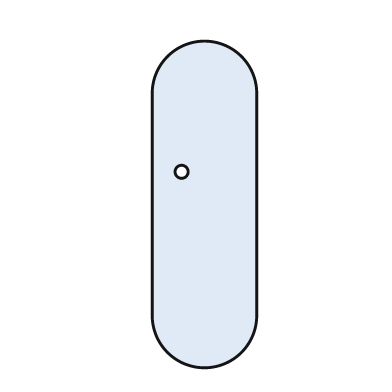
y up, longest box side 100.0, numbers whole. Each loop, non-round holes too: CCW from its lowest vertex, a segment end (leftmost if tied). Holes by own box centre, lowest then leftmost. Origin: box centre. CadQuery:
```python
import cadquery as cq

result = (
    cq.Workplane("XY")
    .moveTo(-16.0, -34.0)
    .threePointArc((0.0, -50.0), (16.0, -34.0))
    .lineTo(16.0, 34.0)
    .threePointArc((0.0, 50.0), (-16.0, 34.0))
    .close()
    .moveTo(-7.0, 10.0)
    .circle(2.0)
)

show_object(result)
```